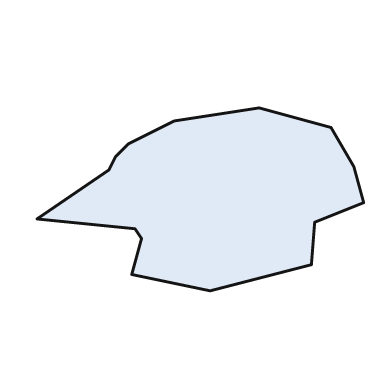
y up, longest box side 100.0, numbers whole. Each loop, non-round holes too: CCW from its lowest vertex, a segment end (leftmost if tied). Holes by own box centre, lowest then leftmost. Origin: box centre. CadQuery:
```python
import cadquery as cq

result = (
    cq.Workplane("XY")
    .moveTo(3.0, -28.0)
    .lineTo(34.0, -20.0)
    .lineTo(35.0, -7.0)
    .lineTo(50.0, -1.0)
    .lineTo(47.0, 10.0)
    .lineTo(40.0, 22.0)
    .lineTo(18.0, 28.0)
    .lineTo(-8.0, 24.0)
    .lineTo(-22.0, 17.0)
    .lineTo(-26.0, 13.0)
    .lineTo(-28.0, 9.0)
    .lineTo(-50.0, -6.0)
    .lineTo(-20.0, -9.0)
    .lineTo(-18.0, -12.0)
    .lineTo(-21.0, -23.0)
    .close()
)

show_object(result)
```